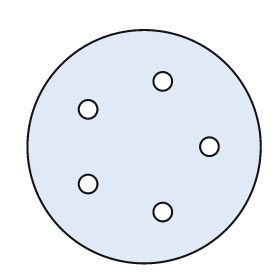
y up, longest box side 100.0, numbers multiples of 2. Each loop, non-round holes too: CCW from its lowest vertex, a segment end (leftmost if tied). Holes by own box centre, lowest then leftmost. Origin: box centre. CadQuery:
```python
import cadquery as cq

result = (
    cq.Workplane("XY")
    .moveTo(0.0, 0.0)
    .circle(50.0)
    .moveTo(8.0, -28.0)
    .circle(4.0)
    .moveTo(-24.0, -16.0)
    .circle(4.0)
    .moveTo(28.0, 0.0)
    .circle(4.0)
    .moveTo(-24.0, 16.0)
    .circle(4.0)
    .moveTo(8.0, 28.0)
    .circle(4.0)
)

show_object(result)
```